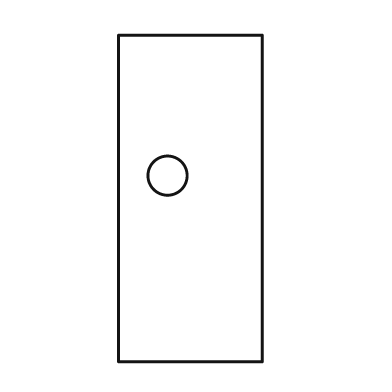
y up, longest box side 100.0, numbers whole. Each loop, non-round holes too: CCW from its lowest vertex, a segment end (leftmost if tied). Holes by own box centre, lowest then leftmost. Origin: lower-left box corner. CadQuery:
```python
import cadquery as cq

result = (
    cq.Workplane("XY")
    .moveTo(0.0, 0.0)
    .lineTo(44.0, 0.0)
    .lineTo(44.0, 100.0)
    .lineTo(0.0, 100.0)
    .close()
    .moveTo(15.0, 57.0)
    .circle(6.0)
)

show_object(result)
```